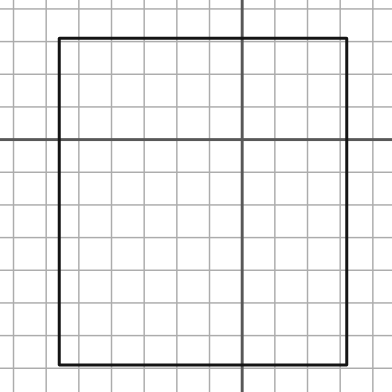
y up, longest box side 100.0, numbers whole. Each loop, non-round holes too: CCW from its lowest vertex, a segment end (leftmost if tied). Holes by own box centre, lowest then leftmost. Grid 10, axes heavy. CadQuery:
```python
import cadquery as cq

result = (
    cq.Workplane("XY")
    .moveTo(-56.0, -69.0)
    .lineTo(32.0, -69.0)
    .lineTo(32.0, 31.0)
    .lineTo(-56.0, 31.0)
    .close()
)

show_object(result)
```